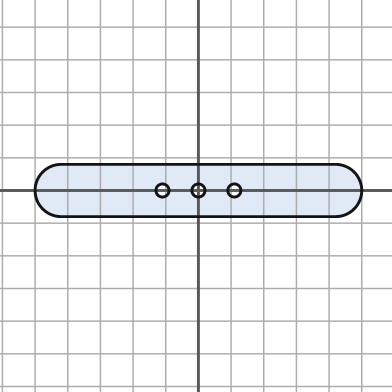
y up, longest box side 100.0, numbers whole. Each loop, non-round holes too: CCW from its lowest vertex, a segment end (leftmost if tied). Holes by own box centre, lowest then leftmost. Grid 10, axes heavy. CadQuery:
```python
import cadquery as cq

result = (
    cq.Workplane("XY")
    .moveTo(-42.0, -8.0)
    .lineTo(42.0, -8.0)
    .threePointArc((50.0, 0.0), (42.0, 8.0))
    .lineTo(-42.0, 8.0)
    .threePointArc((-50.0, 0.0), (-42.0, -8.0))
    .close()
    .moveTo(-11.0, 0.0)
    .circle(2.0)
    .moveTo(0.0, 0.0)
    .circle(2.0)
    .moveTo(11.0, 0.0)
    .circle(2.0)
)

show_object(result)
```